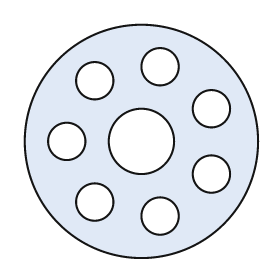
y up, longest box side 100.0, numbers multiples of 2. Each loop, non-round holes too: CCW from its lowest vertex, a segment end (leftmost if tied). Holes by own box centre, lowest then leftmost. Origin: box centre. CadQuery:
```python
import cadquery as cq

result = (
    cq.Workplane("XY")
    .moveTo(0.0, 0.0)
    .circle(50.0)
    .moveTo(8.0, -32.0)
    .circle(8.0)
    .moveTo(-20.0, -26.0)
    .circle(8.0)
    .moveTo(30.0, -14.0)
    .circle(8.0)
    .moveTo(-32.0, 0.0)
    .circle(8.0)
    .moveTo(0.0, 0.0)
    .circle(14.0)
    .moveTo(30.0, 14.0)
    .circle(8.0)
    .moveTo(-20.0, 26.0)
    .circle(8.0)
    .moveTo(8.0, 32.0)
    .circle(8.0)
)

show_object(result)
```